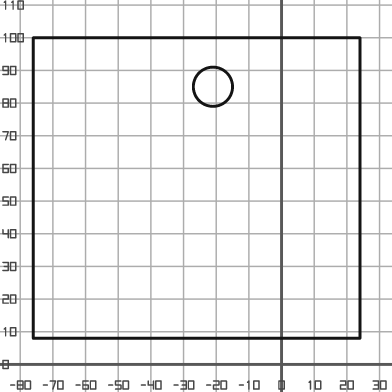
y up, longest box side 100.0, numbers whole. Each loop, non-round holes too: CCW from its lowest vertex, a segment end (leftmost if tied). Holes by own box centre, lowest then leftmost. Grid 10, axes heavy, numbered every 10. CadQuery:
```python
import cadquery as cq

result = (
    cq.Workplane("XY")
    .moveTo(-76.0, 8.0)
    .lineTo(24.0, 8.0)
    .lineTo(24.0, 100.0)
    .lineTo(-76.0, 100.0)
    .close()
    .moveTo(-21.0, 85.0)
    .circle(6.0)
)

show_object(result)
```